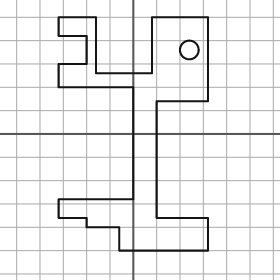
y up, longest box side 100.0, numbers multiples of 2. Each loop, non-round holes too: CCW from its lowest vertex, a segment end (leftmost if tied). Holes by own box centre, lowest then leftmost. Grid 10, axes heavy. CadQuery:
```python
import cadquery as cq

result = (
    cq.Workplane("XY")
    .moveTo(-6.0, -50.0)
    .lineTo(32.0, -50.0)
    .lineTo(32.0, -36.0)
    .lineTo(10.0, -36.0)
    .lineTo(10.0, 14.0)
    .lineTo(32.0, 14.0)
    .lineTo(32.0, 50.0)
    .lineTo(8.0, 50.0)
    .lineTo(8.0, 26.0)
    .lineTo(-16.0, 26.0)
    .lineTo(-16.0, 50.0)
    .lineTo(-32.0, 50.0)
    .lineTo(-32.0, 42.0)
    .lineTo(-20.0, 42.0)
    .lineTo(-20.0, 30.0)
    .lineTo(-32.0, 30.0)
    .lineTo(-32.0, 20.0)
    .lineTo(0.0, 20.0)
    .lineTo(0.0, -28.0)
    .lineTo(-32.0, -28.0)
    .lineTo(-32.0, -36.0)
    .lineTo(-20.0, -36.0)
    .lineTo(-20.0, -40.0)
    .lineTo(-6.0, -40.0)
    .close()
    .moveTo(24.0, 36.0)
    .circle(4.0)
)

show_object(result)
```